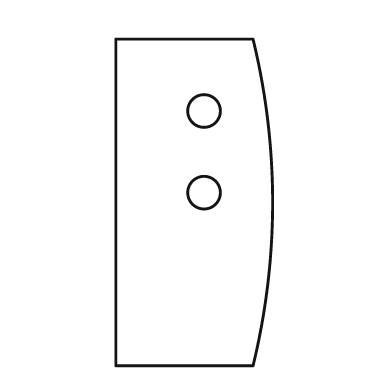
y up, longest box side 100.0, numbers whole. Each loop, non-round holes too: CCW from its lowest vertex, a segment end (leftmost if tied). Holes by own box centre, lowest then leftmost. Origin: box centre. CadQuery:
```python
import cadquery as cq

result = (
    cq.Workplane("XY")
    .moveTo(-24.0, -50.0)
    .lineTo(18.0, -50.0)
    .threePointArc((24.0, 0.0), (18.0, 50.0))
    .lineTo(-24.0, 50.0)
    .close()
    .moveTo(3.0, 3.0)
    .circle(5.0)
    .moveTo(3.0, 28.0)
    .circle(5.0)
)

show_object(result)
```